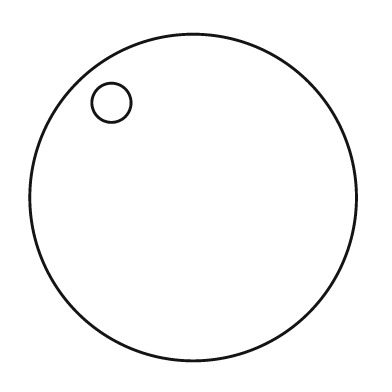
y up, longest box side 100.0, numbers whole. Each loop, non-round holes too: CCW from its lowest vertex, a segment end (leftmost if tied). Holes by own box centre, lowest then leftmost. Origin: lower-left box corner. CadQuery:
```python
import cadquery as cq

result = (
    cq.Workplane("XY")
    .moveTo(50.0, 50.0)
    .circle(50.0)
    .moveTo(25.0, 79.0)
    .circle(6.0)
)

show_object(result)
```